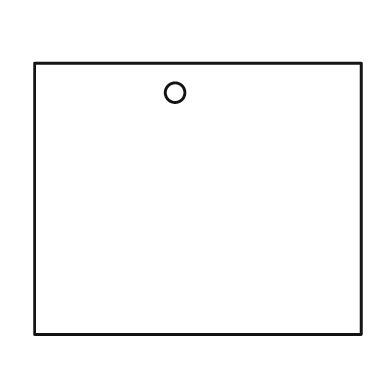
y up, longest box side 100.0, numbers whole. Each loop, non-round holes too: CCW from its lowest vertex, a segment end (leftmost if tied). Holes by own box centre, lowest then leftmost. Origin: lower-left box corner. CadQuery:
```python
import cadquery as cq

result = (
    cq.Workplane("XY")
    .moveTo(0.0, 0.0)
    .lineTo(100.0, 0.0)
    .lineTo(100.0, 83.0)
    .lineTo(0.0, 83.0)
    .close()
    .moveTo(43.0, 74.0)
    .circle(3.0)
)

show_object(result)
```